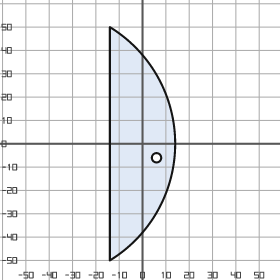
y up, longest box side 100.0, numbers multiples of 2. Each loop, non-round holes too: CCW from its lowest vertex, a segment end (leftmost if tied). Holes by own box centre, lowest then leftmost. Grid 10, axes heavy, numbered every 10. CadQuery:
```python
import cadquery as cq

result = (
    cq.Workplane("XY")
    .moveTo(-14.0, -50.0)
    .threePointArc((14.0, 0.0), (-14.0, 50.0))
    .close()
    .moveTo(6.0, -6.0)
    .circle(2.0)
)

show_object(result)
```